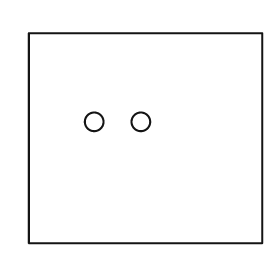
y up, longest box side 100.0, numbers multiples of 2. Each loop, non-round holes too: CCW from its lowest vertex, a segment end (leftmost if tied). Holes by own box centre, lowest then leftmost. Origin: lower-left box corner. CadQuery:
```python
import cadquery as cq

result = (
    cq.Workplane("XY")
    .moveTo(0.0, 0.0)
    .lineTo(100.0, 0.0)
    .lineTo(100.0, 90.0)
    .lineTo(0.0, 90.0)
    .close()
    .moveTo(28.0, 52.0)
    .circle(4.0)
    .moveTo(48.0, 52.0)
    .circle(4.0)
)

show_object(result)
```